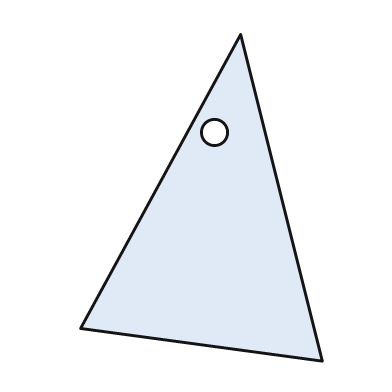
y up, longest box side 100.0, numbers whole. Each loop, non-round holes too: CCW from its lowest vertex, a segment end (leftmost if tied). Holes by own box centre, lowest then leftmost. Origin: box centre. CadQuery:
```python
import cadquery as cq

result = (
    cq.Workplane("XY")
    .moveTo(37.0, -50.0)
    .lineTo(12.0, 50.0)
    .lineTo(-37.0, -40.0)
    .close()
    .moveTo(4.0, 20.0)
    .circle(4.0)
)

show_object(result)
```